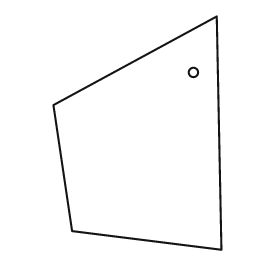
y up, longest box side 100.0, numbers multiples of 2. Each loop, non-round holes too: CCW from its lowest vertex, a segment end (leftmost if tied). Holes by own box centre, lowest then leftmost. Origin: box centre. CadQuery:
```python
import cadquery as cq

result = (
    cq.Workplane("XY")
    .moveTo(36.0, -50.0)
    .lineTo(34.0, 50.0)
    .lineTo(-36.0, 12.0)
    .lineTo(-28.0, -42.0)
    .close()
    .moveTo(24.0, 26.0)
    .circle(2.0)
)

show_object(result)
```